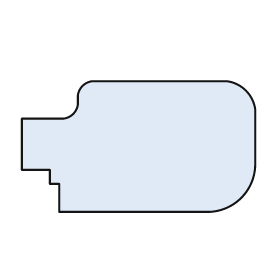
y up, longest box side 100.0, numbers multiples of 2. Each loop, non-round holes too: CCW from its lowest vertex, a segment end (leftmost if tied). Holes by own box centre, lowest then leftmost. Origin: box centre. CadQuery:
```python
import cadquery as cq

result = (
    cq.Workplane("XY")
    .moveTo(-34.0, -28.0)
    .lineTo(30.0, -28.0)
    .threePointArc((44.0, -22.0), (50.0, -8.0))
    .lineTo(50.0, 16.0)
    .threePointArc((46.0, 24.0), (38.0, 28.0))
    .lineTo(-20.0, 28.0)
    .threePointArc((-24.0, 26.0), (-26.0, 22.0))
    .lineTo(-26.0, 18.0)
    .threePointArc((-28.0, 14.0), (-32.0, 12.0))
    .lineTo(-50.0, 12.0)
    .lineTo(-50.0, -10.0)
    .lineTo(-38.0, -10.0)
    .lineTo(-38.0, -16.0)
    .lineTo(-34.0, -16.0)
    .close()
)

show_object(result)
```